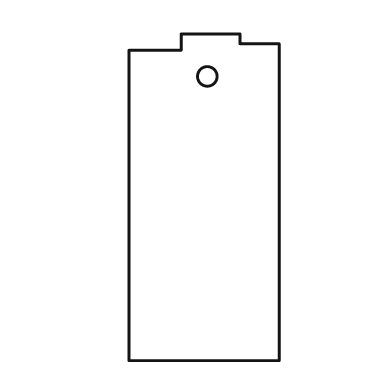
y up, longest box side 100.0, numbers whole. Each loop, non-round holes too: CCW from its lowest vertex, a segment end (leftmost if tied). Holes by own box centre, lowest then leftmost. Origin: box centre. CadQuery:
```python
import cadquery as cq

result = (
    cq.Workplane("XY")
    .moveTo(-23.0, -50.0)
    .lineTo(23.0, -50.0)
    .lineTo(23.0, 47.0)
    .lineTo(11.0, 47.0)
    .lineTo(11.0, 50.0)
    .lineTo(-7.0, 50.0)
    .lineTo(-7.0, 45.0)
    .lineTo(-23.0, 45.0)
    .close()
    .moveTo(1.0, 37.0)
    .circle(3.0)
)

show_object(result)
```